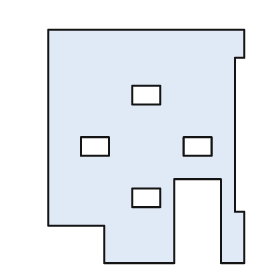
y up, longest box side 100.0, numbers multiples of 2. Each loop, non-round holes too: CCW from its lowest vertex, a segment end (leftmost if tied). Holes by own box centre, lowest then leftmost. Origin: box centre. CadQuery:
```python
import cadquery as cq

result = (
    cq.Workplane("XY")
    .moveTo(-18.0, -50.0)
    .lineTo(12.0, -50.0)
    .lineTo(12.0, -14.0)
    .lineTo(32.0, -14.0)
    .lineTo(32.0, -50.0)
    .lineTo(42.0, -50.0)
    .lineTo(42.0, -28.0)
    .lineTo(38.0, -28.0)
    .lineTo(38.0, 38.0)
    .lineTo(42.0, 38.0)
    .lineTo(42.0, 50.0)
    .lineTo(-42.0, 50.0)
    .lineTo(-42.0, -34.0)
    .lineTo(-18.0, -34.0)
    .close()
    .moveTo(-6.0, -26.0)
    .lineTo(6.0, -26.0)
    .lineTo(6.0, -18.0)
    .lineTo(-6.0, -18.0)
    .close()
    .moveTo(-28.0, -4.0)
    .lineTo(-16.0, -4.0)
    .lineTo(-16.0, 4.0)
    .lineTo(-28.0, 4.0)
    .close()
    .moveTo(16.0, -4.0)
    .lineTo(28.0, -4.0)
    .lineTo(28.0, 4.0)
    .lineTo(16.0, 4.0)
    .close()
    .moveTo(-6.0, 18.0)
    .lineTo(6.0, 18.0)
    .lineTo(6.0, 26.0)
    .lineTo(-6.0, 26.0)
    .close()
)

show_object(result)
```